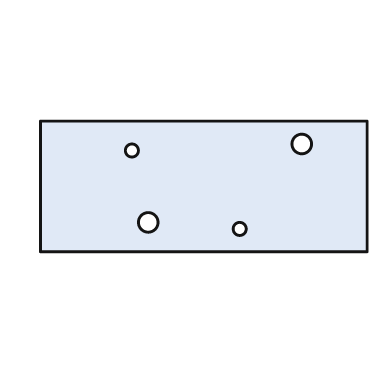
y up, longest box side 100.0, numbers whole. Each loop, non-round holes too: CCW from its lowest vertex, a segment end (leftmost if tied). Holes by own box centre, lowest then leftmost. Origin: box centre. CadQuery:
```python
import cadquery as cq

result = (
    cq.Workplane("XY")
    .moveTo(-50.0, -20.0)
    .lineTo(50.0, -20.0)
    .lineTo(50.0, 20.0)
    .lineTo(-50.0, 20.0)
    .close()
    .moveTo(11.0, -13.0)
    .circle(2.0)
    .moveTo(-17.0, -11.0)
    .circle(3.0)
    .moveTo(-22.0, 11.0)
    .circle(2.0)
    .moveTo(30.0, 13.0)
    .circle(3.0)
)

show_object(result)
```